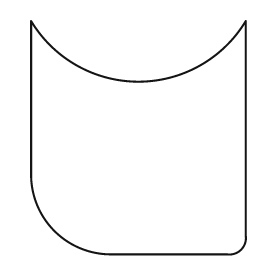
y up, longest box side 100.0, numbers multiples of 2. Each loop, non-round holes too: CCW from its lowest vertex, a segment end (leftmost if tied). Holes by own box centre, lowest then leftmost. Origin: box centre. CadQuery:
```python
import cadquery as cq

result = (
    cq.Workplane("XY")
    .moveTo(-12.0, -50.0)
    .lineTo(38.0, -50.0)
    .threePointArc((44.0, -48.0), (46.0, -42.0))
    .lineTo(46.0, 50.0)
    .threePointArc((0.0, 24.0), (-46.0, 50.0))
    .lineTo(-46.0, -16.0)
    .threePointArc((-36.0, -40.0), (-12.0, -50.0))
    .close()
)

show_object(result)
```